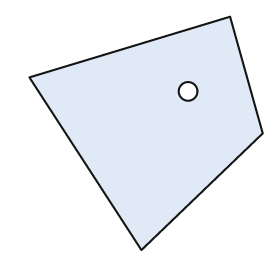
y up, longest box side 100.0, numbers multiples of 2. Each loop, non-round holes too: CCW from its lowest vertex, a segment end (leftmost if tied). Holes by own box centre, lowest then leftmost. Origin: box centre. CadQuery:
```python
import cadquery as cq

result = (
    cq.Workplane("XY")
    .moveTo(-2.0, -50.0)
    .lineTo(50.0, 0.0)
    .lineTo(36.0, 50.0)
    .lineTo(-50.0, 24.0)
    .close()
    .moveTo(18.0, 18.0)
    .circle(4.0)
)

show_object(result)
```